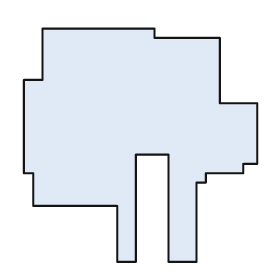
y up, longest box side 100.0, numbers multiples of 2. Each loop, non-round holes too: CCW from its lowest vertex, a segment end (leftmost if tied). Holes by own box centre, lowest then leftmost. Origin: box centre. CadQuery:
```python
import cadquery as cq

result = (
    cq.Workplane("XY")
    .moveTo(-10.0, -50.0)
    .lineTo(-2.0, -50.0)
    .lineTo(-2.0, -4.0)
    .lineTo(12.0, -4.0)
    .lineTo(12.0, -50.0)
    .lineTo(24.0, -50.0)
    .lineTo(24.0, -16.0)
    .lineTo(28.0, -16.0)
    .lineTo(28.0, -12.0)
    .lineTo(44.0, -12.0)
    .lineTo(44.0, -8.0)
    .lineTo(50.0, -8.0)
    .lineTo(50.0, 18.0)
    .lineTo(34.0, 18.0)
    .lineTo(34.0, 46.0)
    .lineTo(6.0, 46.0)
    .lineTo(6.0, 50.0)
    .lineTo(-42.0, 50.0)
    .lineTo(-42.0, 28.0)
    .lineTo(-50.0, 28.0)
    .lineTo(-50.0, -12.0)
    .lineTo(-46.0, -12.0)
    .lineTo(-46.0, -26.0)
    .lineTo(-10.0, -26.0)
    .close()
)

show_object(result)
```